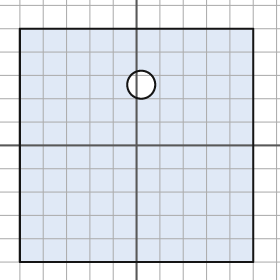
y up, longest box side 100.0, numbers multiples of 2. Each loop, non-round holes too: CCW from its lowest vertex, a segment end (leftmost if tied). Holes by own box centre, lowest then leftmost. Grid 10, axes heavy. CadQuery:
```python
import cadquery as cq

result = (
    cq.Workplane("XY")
    .moveTo(-50.0, -50.0)
    .lineTo(50.0, -50.0)
    .lineTo(50.0, 50.0)
    .lineTo(-50.0, 50.0)
    .close()
    .moveTo(2.0, 26.0)
    .circle(6.0)
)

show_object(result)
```